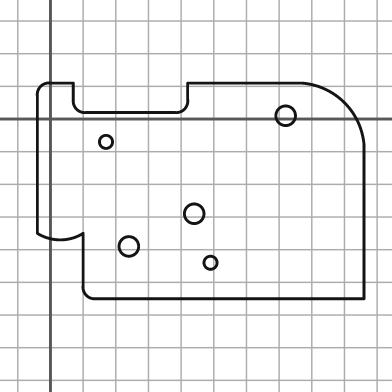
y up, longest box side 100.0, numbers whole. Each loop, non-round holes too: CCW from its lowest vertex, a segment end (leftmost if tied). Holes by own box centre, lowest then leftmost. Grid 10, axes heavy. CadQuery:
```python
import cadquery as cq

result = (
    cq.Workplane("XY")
    .moveTo(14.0, -55.0)
    .lineTo(96.0, -55.0)
    .lineTo(96.0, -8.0)
    .threePointArc((90.0, 5.0), (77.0, 11.0))
    .lineTo(42.0, 11.0)
    .lineTo(42.0, 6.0)
    .threePointArc((41.0, 3.0), (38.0, 2.0))
    .lineTo(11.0, 2.0)
    .threePointArc((8.0, 3.0), (7.0, 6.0))
    .lineTo(7.0, 11.0)
    .lineTo(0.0, 11.0)
    .threePointArc((-3.0, 10.0), (-4.0, 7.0))
    .lineTo(-4.0, -35.0)
    .threePointArc((3.0, -37.0), (10.0, -35.0))
    .lineTo(10.0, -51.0)
    .threePointArc((11.0, -54.0), (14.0, -55.0))
    .close()
    .moveTo(49.0, -44.0)
    .circle(2.0)
    .moveTo(24.0, -39.0)
    .circle(3.0)
    .moveTo(44.0, -29.0)
    .circle(3.0)
    .moveTo(17.0, -7.0)
    .circle(2.0)
    .moveTo(72.0, 1.0)
    .circle(3.0)
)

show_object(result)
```